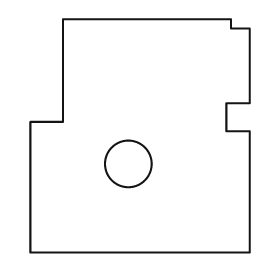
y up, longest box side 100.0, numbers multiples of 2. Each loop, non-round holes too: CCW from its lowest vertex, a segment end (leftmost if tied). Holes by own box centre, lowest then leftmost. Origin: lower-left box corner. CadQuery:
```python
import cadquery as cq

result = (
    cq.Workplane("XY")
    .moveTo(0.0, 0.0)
    .lineTo(94.0, 0.0)
    .lineTo(94.0, 52.0)
    .lineTo(84.0, 52.0)
    .lineTo(84.0, 64.0)
    .lineTo(94.0, 64.0)
    .lineTo(94.0, 96.0)
    .lineTo(86.0, 96.0)
    .lineTo(86.0, 100.0)
    .lineTo(14.0, 100.0)
    .lineTo(14.0, 56.0)
    .lineTo(0.0, 56.0)
    .close()
    .moveTo(42.0, 38.0)
    .circle(10.0)
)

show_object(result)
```